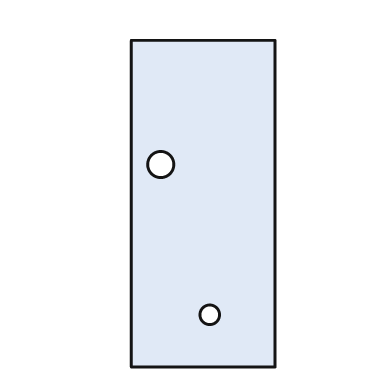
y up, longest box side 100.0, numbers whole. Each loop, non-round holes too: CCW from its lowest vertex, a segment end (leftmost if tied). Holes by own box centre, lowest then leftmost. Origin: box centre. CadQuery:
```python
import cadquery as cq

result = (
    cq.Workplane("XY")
    .moveTo(-22.0, -50.0)
    .lineTo(22.0, -50.0)
    .lineTo(22.0, 50.0)
    .lineTo(-22.0, 50.0)
    .close()
    .moveTo(2.0, -34.0)
    .circle(3.0)
    .moveTo(-13.0, 12.0)
    .circle(4.0)
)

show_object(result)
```